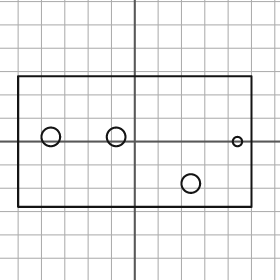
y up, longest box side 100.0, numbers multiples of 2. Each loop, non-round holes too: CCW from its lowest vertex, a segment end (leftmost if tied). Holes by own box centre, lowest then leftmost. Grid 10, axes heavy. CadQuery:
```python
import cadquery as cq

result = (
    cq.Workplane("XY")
    .moveTo(-50.0, -28.0)
    .lineTo(50.0, -28.0)
    .lineTo(50.0, 28.0)
    .lineTo(-50.0, 28.0)
    .close()
    .moveTo(24.0, -18.0)
    .circle(4.0)
    .moveTo(44.0, 0.0)
    .circle(2.0)
    .moveTo(-36.0, 2.0)
    .circle(4.0)
    .moveTo(-8.0, 2.0)
    .circle(4.0)
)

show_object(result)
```